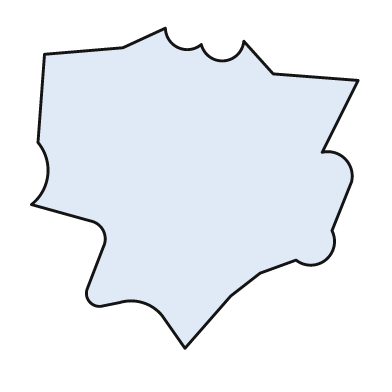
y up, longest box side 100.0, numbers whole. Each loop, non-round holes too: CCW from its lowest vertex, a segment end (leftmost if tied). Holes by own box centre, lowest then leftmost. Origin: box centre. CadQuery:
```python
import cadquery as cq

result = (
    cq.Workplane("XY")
    .moveTo(-3.0, -49.0)
    .lineTo(11.0, -33.0)
    .lineTo(20.0, -26.0)
    .lineTo(31.0, -22.0)
    .threePointArc((40.0, -22.0), (42.0, -13.0))
    .lineTo(48.0, 2.0)
    .threePointArc((46.0, 9.0), (39.0, 11.0))
    .lineTo(50.0, 33.0)
    .lineTo(24.0, 35.0)
    .lineTo(15.0, 45.0)
    .threePointArc((9.0, 39.0), (2.0, 44.0))
    .threePointArc((-5.0, 43.0), (-9.0, 49.0))
    .lineTo(-22.0, 43.0)
    .lineTo(-46.0, 41.0)
    .lineTo(-48.0, 14.0)
    .threePointArc((-45.0, 4.0), (-50.0, -5.0))
    .lineTo(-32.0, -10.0)
    .threePointArc((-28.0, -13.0), (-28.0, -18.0))
    .lineTo(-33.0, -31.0)
    .threePointArc((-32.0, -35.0), (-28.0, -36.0))
    .lineTo(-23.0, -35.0)
    .threePointArc((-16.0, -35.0), (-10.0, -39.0))
    .close()
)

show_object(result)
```